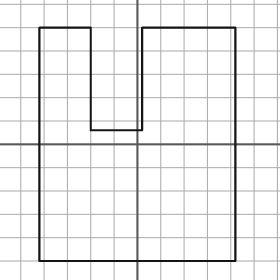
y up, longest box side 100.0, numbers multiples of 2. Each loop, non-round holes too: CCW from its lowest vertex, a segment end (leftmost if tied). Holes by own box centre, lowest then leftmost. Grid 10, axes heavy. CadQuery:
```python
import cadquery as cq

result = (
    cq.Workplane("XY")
    .moveTo(-42.0, -50.0)
    .lineTo(42.0, -50.0)
    .lineTo(42.0, 50.0)
    .lineTo(2.0, 50.0)
    .lineTo(2.0, 6.0)
    .lineTo(-20.0, 6.0)
    .lineTo(-20.0, 50.0)
    .lineTo(-42.0, 50.0)
    .close()
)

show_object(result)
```